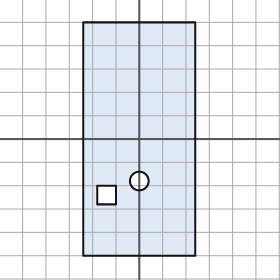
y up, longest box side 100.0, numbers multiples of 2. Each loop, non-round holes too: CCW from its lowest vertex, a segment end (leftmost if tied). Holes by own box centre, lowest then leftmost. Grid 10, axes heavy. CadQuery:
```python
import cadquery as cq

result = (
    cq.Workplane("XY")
    .moveTo(-24.0, -50.0)
    .lineTo(24.0, -50.0)
    .lineTo(24.0, 50.0)
    .lineTo(-24.0, 50.0)
    .close()
    .moveTo(-18.0, -28.0)
    .lineTo(-10.0, -28.0)
    .lineTo(-10.0, -20.0)
    .lineTo(-18.0, -20.0)
    .close()
    .moveTo(0.0, -18.0)
    .circle(4.0)
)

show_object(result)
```